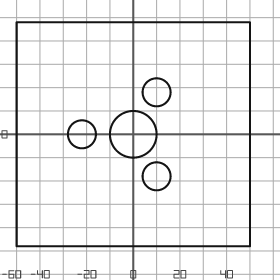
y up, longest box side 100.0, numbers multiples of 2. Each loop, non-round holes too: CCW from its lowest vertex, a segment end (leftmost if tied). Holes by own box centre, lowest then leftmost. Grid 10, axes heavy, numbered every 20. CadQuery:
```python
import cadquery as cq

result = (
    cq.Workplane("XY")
    .moveTo(-50.0, -48.0)
    .lineTo(50.0, -48.0)
    .lineTo(50.0, 48.0)
    .lineTo(-50.0, 48.0)
    .close()
    .moveTo(10.0, -18.0)
    .circle(6.0)
    .moveTo(-22.0, 0.0)
    .circle(6.0)
    .moveTo(0.0, 0.0)
    .circle(10.0)
    .moveTo(10.0, 18.0)
    .circle(6.0)
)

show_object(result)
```